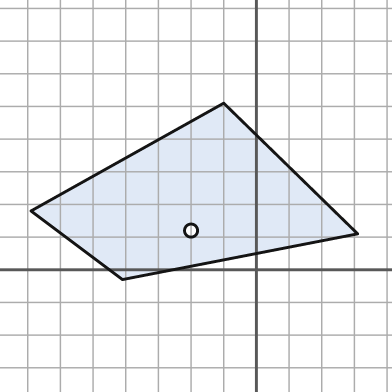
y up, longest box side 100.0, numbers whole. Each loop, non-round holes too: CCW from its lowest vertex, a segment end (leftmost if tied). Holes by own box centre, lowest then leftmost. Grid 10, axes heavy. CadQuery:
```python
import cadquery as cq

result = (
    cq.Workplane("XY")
    .moveTo(-41.0, -3.0)
    .lineTo(31.0, 11.0)
    .lineTo(-10.0, 51.0)
    .lineTo(-69.0, 18.0)
    .close()
    .moveTo(-20.0, 12.0)
    .circle(2.0)
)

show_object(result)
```